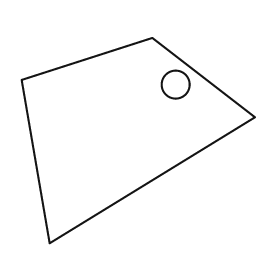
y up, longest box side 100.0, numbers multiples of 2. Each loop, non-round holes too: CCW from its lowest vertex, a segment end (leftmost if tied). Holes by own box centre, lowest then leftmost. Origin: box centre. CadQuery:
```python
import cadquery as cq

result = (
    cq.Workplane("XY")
    .moveTo(-38.0, -44.0)
    .lineTo(50.0, 10.0)
    .lineTo(6.0, 44.0)
    .lineTo(-50.0, 26.0)
    .close()
    .moveTo(16.0, 24.0)
    .circle(6.0)
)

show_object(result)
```